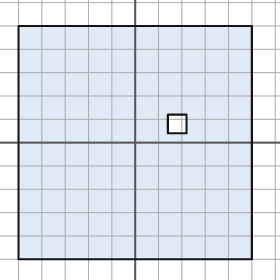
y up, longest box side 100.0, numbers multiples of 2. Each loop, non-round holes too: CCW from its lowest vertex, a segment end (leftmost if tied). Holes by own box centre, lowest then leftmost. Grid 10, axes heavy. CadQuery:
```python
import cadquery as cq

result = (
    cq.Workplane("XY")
    .moveTo(-50.0, -50.0)
    .lineTo(50.0, -50.0)
    .lineTo(50.0, 50.0)
    .lineTo(-50.0, 50.0)
    .close()
    .moveTo(14.0, 4.0)
    .lineTo(22.0, 4.0)
    .lineTo(22.0, 12.0)
    .lineTo(14.0, 12.0)
    .close()
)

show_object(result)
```